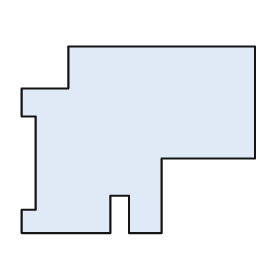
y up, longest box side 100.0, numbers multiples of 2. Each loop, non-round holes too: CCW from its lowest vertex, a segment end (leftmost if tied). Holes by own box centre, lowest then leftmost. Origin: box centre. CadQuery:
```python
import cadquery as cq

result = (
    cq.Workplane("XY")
    .moveTo(-50.0, -40.0)
    .lineTo(-12.0, -40.0)
    .lineTo(-12.0, -24.0)
    .lineTo(-4.0, -24.0)
    .lineTo(-4.0, -40.0)
    .lineTo(10.0, -40.0)
    .lineTo(10.0, -8.0)
    .lineTo(50.0, -8.0)
    .lineTo(50.0, 40.0)
    .lineTo(-30.0, 40.0)
    .lineTo(-30.0, 22.0)
    .lineTo(-50.0, 22.0)
    .lineTo(-50.0, 10.0)
    .lineTo(-44.0, 10.0)
    .lineTo(-44.0, -30.0)
    .lineTo(-50.0, -30.0)
    .close()
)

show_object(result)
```